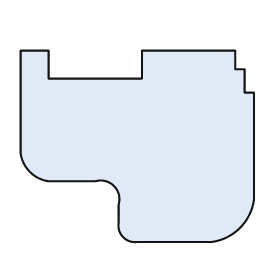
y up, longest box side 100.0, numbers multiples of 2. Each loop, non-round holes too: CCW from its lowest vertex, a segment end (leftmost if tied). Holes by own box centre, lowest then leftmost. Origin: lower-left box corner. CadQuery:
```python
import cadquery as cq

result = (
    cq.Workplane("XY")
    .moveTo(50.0, 0.0)
    .lineTo(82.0, 0.0)
    .threePointArc((94.0, 6.0), (100.0, 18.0))
    .lineTo(100.0, 64.0)
    .lineTo(96.0, 64.0)
    .lineTo(96.0, 74.0)
    .lineTo(92.0, 74.0)
    .lineTo(92.0, 82.0)
    .lineTo(52.0, 82.0)
    .lineTo(52.0, 70.0)
    .lineTo(12.0, 70.0)
    .lineTo(12.0, 82.0)
    .lineTo(0.0, 82.0)
    .lineTo(0.0, 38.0)
    .threePointArc((4.0, 30.0), (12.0, 26.0))
    .lineTo(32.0, 26.0)
    .threePointArc((40.0, 24.0), (42.0, 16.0))
    .lineTo(42.0, 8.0)
    .threePointArc((44.0, 2.0), (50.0, 0.0))
    .close()
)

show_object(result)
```